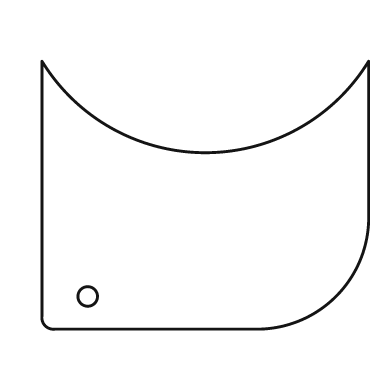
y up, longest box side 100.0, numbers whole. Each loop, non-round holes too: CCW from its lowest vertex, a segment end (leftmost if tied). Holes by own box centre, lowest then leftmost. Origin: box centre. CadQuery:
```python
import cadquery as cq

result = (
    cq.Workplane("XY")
    .moveTo(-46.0, -41.0)
    .lineTo(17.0, -41.0)
    .threePointArc((40.0, -31.0), (50.0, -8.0))
    .lineTo(50.0, 41.0)
    .threePointArc((0.0, 13.0), (-50.0, 41.0))
    .lineTo(-50.0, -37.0)
    .threePointArc((-49.0, -40.0), (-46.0, -41.0))
    .close()
    .moveTo(-36.0, -31.0)
    .circle(3.0)
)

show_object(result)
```